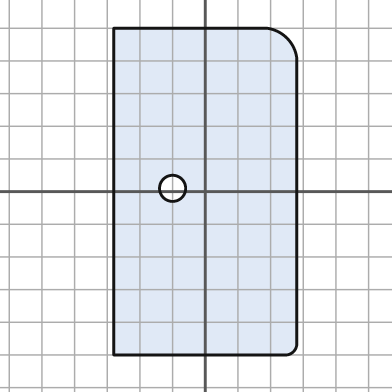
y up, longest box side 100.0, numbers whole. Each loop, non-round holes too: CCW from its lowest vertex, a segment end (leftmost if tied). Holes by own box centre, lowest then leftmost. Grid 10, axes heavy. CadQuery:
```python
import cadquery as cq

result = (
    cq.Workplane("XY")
    .moveTo(-28.0, -50.0)
    .lineTo(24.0, -50.0)
    .threePointArc((27.0, -49.0), (28.0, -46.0))
    .lineTo(28.0, 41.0)
    .threePointArc((25.0, 47.0), (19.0, 50.0))
    .lineTo(-28.0, 50.0)
    .close()
    .moveTo(-10.0, 1.0)
    .circle(4.0)
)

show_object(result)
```